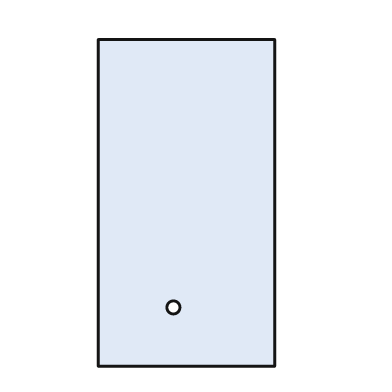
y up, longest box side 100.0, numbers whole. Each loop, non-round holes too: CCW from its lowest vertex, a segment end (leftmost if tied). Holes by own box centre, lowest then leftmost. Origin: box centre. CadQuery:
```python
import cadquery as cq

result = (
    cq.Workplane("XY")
    .moveTo(-27.0, -50.0)
    .lineTo(27.0, -50.0)
    .lineTo(27.0, 50.0)
    .lineTo(-27.0, 50.0)
    .close()
    .moveTo(-4.0, -32.0)
    .circle(2.0)
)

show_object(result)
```